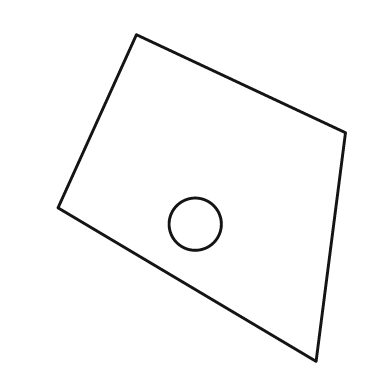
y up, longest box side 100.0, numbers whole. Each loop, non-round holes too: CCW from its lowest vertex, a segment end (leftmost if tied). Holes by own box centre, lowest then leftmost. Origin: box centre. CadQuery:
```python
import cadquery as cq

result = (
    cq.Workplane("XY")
    .moveTo(35.0, -50.0)
    .lineTo(44.0, 20.0)
    .lineTo(-20.0, 50.0)
    .lineTo(-44.0, -3.0)
    .close()
    .moveTo(-2.0, -8.0)
    .circle(8.0)
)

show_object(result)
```